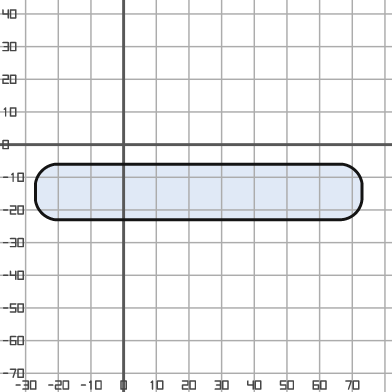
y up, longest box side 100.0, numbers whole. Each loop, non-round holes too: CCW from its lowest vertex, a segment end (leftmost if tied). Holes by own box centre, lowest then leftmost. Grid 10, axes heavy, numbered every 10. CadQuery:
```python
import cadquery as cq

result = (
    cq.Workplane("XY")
    .moveTo(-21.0, -23.0)
    .lineTo(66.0, -23.0)
    .threePointArc((71.0, -21.0), (73.0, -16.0))
    .lineTo(73.0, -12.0)
    .threePointArc((71.0, -8.0), (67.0, -6.0))
    .lineTo(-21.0, -6.0)
    .threePointArc((-25.0, -8.0), (-27.0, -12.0))
    .lineTo(-27.0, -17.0)
    .threePointArc((-25.0, -21.0), (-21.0, -23.0))
    .close()
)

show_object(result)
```